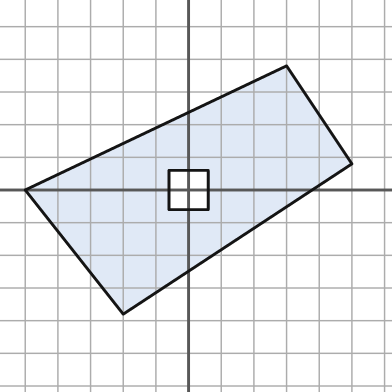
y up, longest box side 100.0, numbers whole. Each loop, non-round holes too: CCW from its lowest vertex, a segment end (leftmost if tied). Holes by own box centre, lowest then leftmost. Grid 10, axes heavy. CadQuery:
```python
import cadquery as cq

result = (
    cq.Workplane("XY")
    .moveTo(-20.0, -38.0)
    .lineTo(50.0, 8.0)
    .lineTo(30.0, 38.0)
    .lineTo(-50.0, 0.0)
    .close()
    .moveTo(-6.0, -6.0)
    .lineTo(6.0, -6.0)
    .lineTo(6.0, 6.0)
    .lineTo(-6.0, 6.0)
    .close()
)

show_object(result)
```